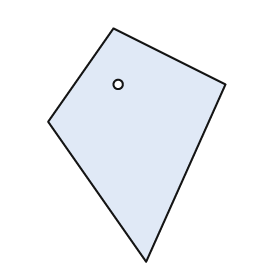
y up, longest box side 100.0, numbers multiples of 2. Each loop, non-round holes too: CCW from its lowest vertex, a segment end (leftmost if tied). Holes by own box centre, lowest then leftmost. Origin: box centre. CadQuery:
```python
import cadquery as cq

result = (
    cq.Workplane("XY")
    .moveTo(4.0, -50.0)
    .lineTo(38.0, 26.0)
    .lineTo(-10.0, 50.0)
    .lineTo(-38.0, 10.0)
    .close()
    .moveTo(-8.0, 26.0)
    .circle(2.0)
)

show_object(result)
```